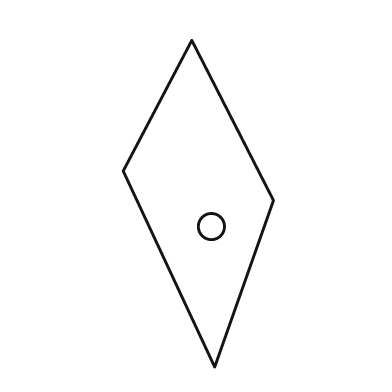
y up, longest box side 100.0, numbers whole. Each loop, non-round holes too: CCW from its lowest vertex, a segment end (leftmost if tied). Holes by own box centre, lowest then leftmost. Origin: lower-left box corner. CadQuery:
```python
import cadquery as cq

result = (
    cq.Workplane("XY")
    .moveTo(28.0, 0.0)
    .lineTo(46.0, 51.0)
    .lineTo(21.0, 100.0)
    .lineTo(0.0, 60.0)
    .close()
    .moveTo(27.0, 43.0)
    .circle(4.0)
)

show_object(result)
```